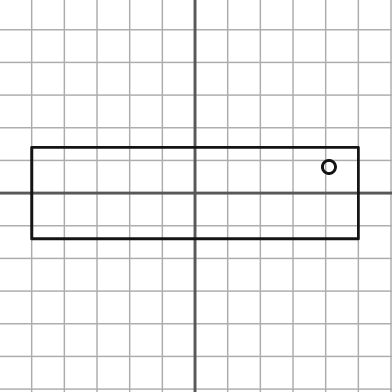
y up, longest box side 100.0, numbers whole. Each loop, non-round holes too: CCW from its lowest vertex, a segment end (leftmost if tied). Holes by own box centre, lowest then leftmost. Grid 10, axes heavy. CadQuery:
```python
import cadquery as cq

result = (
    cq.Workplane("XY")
    .moveTo(-50.0, -14.0)
    .lineTo(50.0, -14.0)
    .lineTo(50.0, 14.0)
    .lineTo(-50.0, 14.0)
    .close()
    .moveTo(41.0, 8.0)
    .circle(2.0)
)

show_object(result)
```